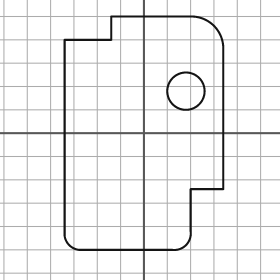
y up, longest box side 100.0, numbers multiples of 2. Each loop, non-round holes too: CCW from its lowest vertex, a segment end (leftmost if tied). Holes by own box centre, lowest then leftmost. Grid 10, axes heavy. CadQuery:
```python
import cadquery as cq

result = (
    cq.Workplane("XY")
    .moveTo(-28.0, -50.0)
    .lineTo(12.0, -50.0)
    .threePointArc((18.0, -48.0), (20.0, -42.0))
    .lineTo(20.0, -24.0)
    .lineTo(34.0, -24.0)
    .lineTo(34.0, 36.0)
    .threePointArc((30.0, 46.0), (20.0, 50.0))
    .lineTo(-14.0, 50.0)
    .lineTo(-14.0, 40.0)
    .lineTo(-34.0, 40.0)
    .lineTo(-34.0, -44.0)
    .threePointArc((-32.0, -48.0), (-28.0, -50.0))
    .close()
    .moveTo(18.0, 18.0)
    .circle(8.0)
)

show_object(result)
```